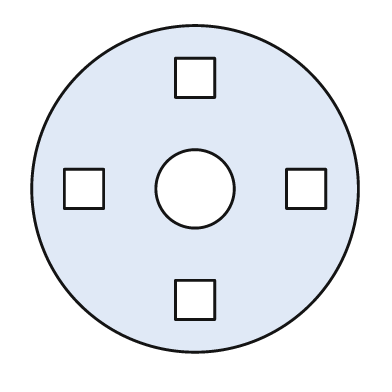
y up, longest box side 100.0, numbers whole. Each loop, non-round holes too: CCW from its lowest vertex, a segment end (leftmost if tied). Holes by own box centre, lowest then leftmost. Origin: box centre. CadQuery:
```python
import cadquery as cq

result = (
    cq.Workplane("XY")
    .moveTo(0.0, 0.0)
    .circle(50.0)
    .moveTo(-6.0, -40.0)
    .lineTo(6.0, -40.0)
    .lineTo(6.0, -28.0)
    .lineTo(-6.0, -28.0)
    .close()
    .moveTo(-40.0, -6.0)
    .lineTo(-28.0, -6.0)
    .lineTo(-28.0, 6.0)
    .lineTo(-40.0, 6.0)
    .close()
    .moveTo(0.0, 0.0)
    .circle(12.0)
    .moveTo(28.0, -6.0)
    .lineTo(40.0, -6.0)
    .lineTo(40.0, 6.0)
    .lineTo(28.0, 6.0)
    .close()
    .moveTo(-6.0, 28.0)
    .lineTo(6.0, 28.0)
    .lineTo(6.0, 40.0)
    .lineTo(-6.0, 40.0)
    .close()
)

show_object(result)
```